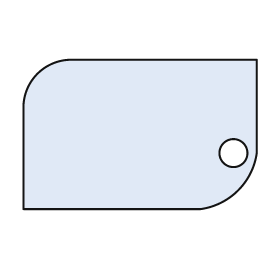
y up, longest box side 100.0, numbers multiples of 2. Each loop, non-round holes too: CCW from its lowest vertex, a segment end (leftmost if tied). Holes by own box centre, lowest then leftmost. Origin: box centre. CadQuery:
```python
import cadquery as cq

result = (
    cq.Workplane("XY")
    .moveTo(-50.0, -32.0)
    .lineTo(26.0, -32.0)
    .threePointArc((42.0, -24.0), (50.0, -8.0))
    .lineTo(50.0, 32.0)
    .lineTo(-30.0, 32.0)
    .threePointArc((-44.0, 26.0), (-50.0, 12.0))
    .close()
    .moveTo(40.0, -8.0)
    .circle(6.0)
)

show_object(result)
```